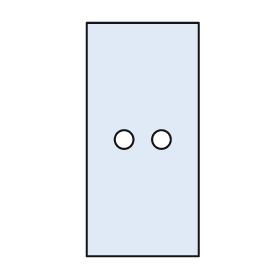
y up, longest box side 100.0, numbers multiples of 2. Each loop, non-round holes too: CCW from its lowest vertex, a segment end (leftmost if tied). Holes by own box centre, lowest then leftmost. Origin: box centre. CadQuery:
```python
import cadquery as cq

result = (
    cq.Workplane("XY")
    .moveTo(-24.0, -50.0)
    .lineTo(24.0, -50.0)
    .lineTo(24.0, 50.0)
    .lineTo(-24.0, 50.0)
    .close()
    .moveTo(-8.0, 0.0)
    .circle(4.0)
    .moveTo(8.0, 0.0)
    .circle(4.0)
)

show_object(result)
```